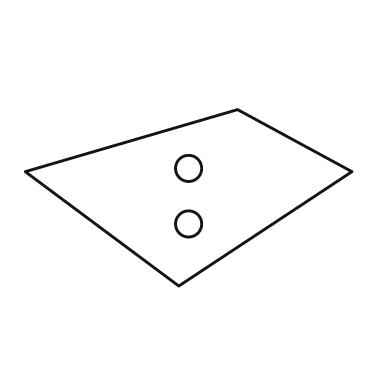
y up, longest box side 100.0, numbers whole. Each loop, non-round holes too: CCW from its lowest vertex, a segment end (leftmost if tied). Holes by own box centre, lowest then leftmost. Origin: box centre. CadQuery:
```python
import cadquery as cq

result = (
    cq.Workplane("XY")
    .moveTo(-3.0, -27.0)
    .lineTo(50.0, 8.0)
    .lineTo(15.0, 27.0)
    .lineTo(-50.0, 8.0)
    .close()
    .moveTo(0.0, -8.0)
    .circle(4.0)
    .moveTo(0.0, 9.0)
    .circle(4.0)
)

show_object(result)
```